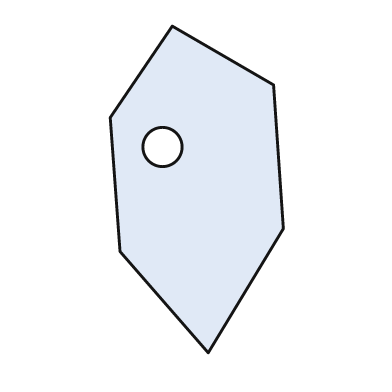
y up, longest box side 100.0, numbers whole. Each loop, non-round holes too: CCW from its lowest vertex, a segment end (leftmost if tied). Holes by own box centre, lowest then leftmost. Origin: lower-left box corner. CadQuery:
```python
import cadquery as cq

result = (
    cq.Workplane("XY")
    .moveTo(30.0, 0.0)
    .lineTo(53.0, 38.0)
    .lineTo(50.0, 82.0)
    .lineTo(19.0, 100.0)
    .lineTo(0.0, 72.0)
    .lineTo(3.0, 31.0)
    .close()
    .moveTo(16.0, 63.0)
    .circle(6.0)
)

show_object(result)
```